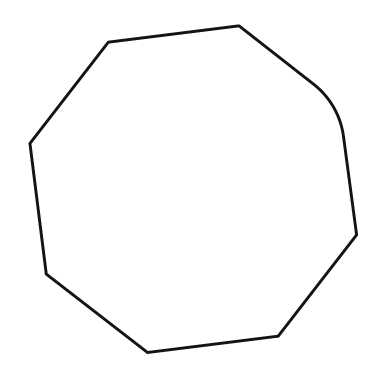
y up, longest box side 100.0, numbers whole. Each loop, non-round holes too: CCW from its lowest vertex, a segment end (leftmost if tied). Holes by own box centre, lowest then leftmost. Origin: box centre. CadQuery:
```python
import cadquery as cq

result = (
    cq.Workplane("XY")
    .moveTo(-14.0, -50.0)
    .lineTo(26.0, -45.0)
    .lineTo(50.0, -14.0)
    .lineTo(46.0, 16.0)
    .threePointArc((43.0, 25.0), (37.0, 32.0))
    .lineTo(14.0, 50.0)
    .lineTo(-26.0, 45.0)
    .lineTo(-50.0, 14.0)
    .lineTo(-45.0, -26.0)
    .close()
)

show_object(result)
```